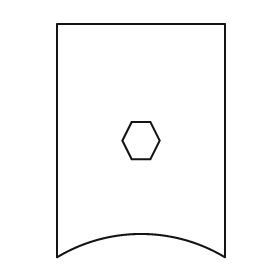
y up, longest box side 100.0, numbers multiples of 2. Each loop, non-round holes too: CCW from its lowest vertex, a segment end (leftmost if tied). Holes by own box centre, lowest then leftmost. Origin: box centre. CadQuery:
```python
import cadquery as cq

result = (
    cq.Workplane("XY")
    .moveTo(-36.0, -50.0)
    .threePointArc((0.0, -40.0), (36.0, -50.0))
    .lineTo(36.0, 50.0)
    .lineTo(-36.0, 50.0)
    .close()
    .moveTo(-4.0, -8.0)
    .lineTo(4.0, -8.0)
    .lineTo(8.0, 0.0)
    .lineTo(4.0, 8.0)
    .lineTo(-4.0, 8.0)
    .lineTo(-8.0, 0.0)
    .close()
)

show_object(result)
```